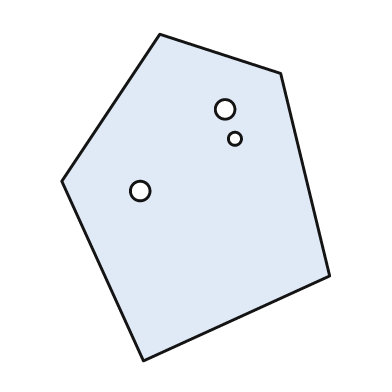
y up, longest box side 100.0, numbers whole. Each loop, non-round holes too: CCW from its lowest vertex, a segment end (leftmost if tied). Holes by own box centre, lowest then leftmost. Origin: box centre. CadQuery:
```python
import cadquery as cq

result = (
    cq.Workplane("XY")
    .moveTo(-16.0, -50.0)
    .lineTo(41.0, -24.0)
    .lineTo(26.0, 38.0)
    .lineTo(-11.0, 50.0)
    .lineTo(-41.0, 5.0)
    .close()
    .moveTo(-17.0, 2.0)
    .circle(3.0)
    .moveTo(12.0, 18.0)
    .circle(2.0)
    .moveTo(9.0, 27.0)
    .circle(3.0)
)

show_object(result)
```